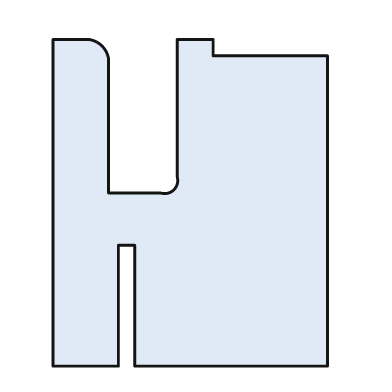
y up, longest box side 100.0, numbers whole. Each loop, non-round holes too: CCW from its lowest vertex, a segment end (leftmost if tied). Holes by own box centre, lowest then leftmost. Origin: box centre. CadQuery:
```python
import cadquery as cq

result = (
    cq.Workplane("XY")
    .moveTo(-42.0, -50.0)
    .lineTo(-22.0, -50.0)
    .lineTo(-22.0, -13.0)
    .lineTo(-17.0, -13.0)
    .lineTo(-17.0, -50.0)
    .lineTo(42.0, -50.0)
    .lineTo(42.0, 45.0)
    .lineTo(7.0, 45.0)
    .lineTo(7.0, 50.0)
    .lineTo(-4.0, 50.0)
    .lineTo(-4.0, 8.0)
    .threePointArc((-5.0, 4.0), (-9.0, 3.0))
    .lineTo(-25.0, 3.0)
    .lineTo(-25.0, 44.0)
    .threePointArc((-27.0, 48.0), (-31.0, 50.0))
    .lineTo(-42.0, 50.0)
    .close()
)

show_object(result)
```